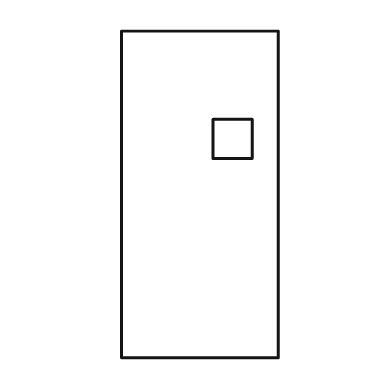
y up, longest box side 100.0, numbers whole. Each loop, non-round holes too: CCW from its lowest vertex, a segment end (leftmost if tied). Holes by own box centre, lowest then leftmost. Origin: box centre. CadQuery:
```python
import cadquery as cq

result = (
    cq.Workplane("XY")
    .moveTo(-24.0, -50.0)
    .lineTo(24.0, -50.0)
    .lineTo(24.0, 50.0)
    .lineTo(-24.0, 50.0)
    .close()
    .moveTo(4.0, 11.0)
    .lineTo(16.0, 11.0)
    .lineTo(16.0, 23.0)
    .lineTo(4.0, 23.0)
    .close()
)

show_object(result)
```